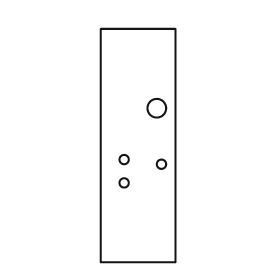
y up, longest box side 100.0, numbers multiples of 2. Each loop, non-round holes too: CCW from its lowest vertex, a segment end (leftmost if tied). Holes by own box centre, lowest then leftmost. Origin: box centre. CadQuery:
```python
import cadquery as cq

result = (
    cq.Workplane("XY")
    .moveTo(-16.0, -50.0)
    .lineTo(16.0, -50.0)
    .lineTo(16.0, 50.0)
    .lineTo(-16.0, 50.0)
    .close()
    .moveTo(-6.0, -16.0)
    .circle(2.0)
    .moveTo(10.0, -8.0)
    .circle(2.0)
    .moveTo(-6.0, -6.0)
    .circle(2.0)
    .moveTo(8.0, 16.0)
    .circle(4.0)
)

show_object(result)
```